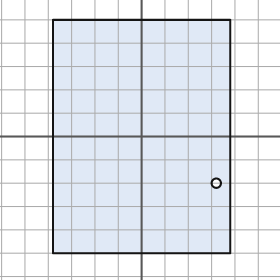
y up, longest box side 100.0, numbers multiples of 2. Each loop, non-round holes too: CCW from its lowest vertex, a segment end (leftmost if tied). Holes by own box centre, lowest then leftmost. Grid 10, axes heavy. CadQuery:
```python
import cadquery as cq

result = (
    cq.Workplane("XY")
    .moveTo(-38.0, -50.0)
    .lineTo(38.0, -50.0)
    .lineTo(38.0, 50.0)
    .lineTo(-38.0, 50.0)
    .close()
    .moveTo(32.0, -20.0)
    .circle(2.0)
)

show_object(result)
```